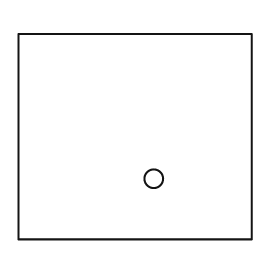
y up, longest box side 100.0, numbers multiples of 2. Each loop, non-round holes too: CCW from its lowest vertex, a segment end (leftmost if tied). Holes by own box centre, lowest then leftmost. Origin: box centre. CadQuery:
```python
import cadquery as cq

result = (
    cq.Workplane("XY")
    .moveTo(-50.0, -44.0)
    .lineTo(50.0, -44.0)
    .lineTo(50.0, 44.0)
    .lineTo(-50.0, 44.0)
    .close()
    .moveTo(8.0, -18.0)
    .circle(4.0)
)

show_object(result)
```